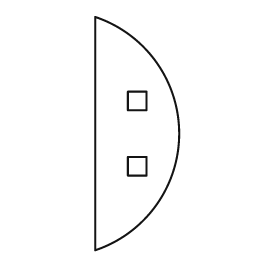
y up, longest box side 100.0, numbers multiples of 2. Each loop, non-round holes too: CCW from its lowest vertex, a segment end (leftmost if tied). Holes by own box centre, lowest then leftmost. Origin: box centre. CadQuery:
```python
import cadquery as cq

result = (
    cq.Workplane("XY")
    .moveTo(-18.0, -50.0)
    .threePointArc((18.0, 0.0), (-18.0, 50.0))
    .close()
    .moveTo(-4.0, -18.0)
    .lineTo(4.0, -18.0)
    .lineTo(4.0, -10.0)
    .lineTo(-4.0, -10.0)
    .close()
    .moveTo(-4.0, 10.0)
    .lineTo(4.0, 10.0)
    .lineTo(4.0, 18.0)
    .lineTo(-4.0, 18.0)
    .close()
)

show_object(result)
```